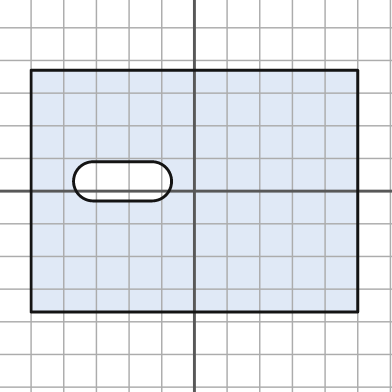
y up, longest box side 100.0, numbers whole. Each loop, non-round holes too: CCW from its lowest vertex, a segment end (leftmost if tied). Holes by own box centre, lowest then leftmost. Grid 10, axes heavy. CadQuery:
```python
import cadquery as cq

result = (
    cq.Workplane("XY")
    .moveTo(-50.0, -37.0)
    .lineTo(50.0, -37.0)
    .lineTo(50.0, 37.0)
    .lineTo(-50.0, 37.0)
    .close()
    .moveTo(-31.0, -3.0)
    .lineTo(-13.0, -3.0)
    .threePointArc((-7.0, 3.0), (-13.0, 9.0))
    .lineTo(-31.0, 9.0)
    .threePointArc((-37.0, 3.0), (-31.0, -3.0))
    .close()
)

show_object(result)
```